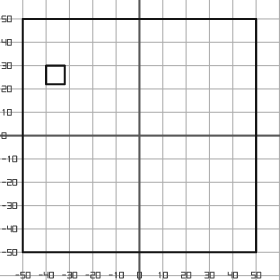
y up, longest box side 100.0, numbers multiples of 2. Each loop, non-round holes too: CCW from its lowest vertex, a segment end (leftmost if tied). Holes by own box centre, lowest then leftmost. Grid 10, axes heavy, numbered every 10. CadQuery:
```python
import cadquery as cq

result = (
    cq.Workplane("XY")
    .moveTo(-50.0, -50.0)
    .lineTo(50.0, -50.0)
    .lineTo(50.0, 50.0)
    .lineTo(-50.0, 50.0)
    .close()
    .moveTo(-40.0, 22.0)
    .lineTo(-32.0, 22.0)
    .lineTo(-32.0, 30.0)
    .lineTo(-40.0, 30.0)
    .close()
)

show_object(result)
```